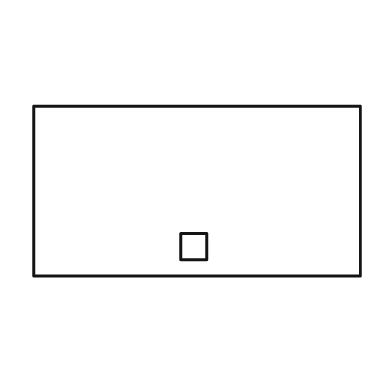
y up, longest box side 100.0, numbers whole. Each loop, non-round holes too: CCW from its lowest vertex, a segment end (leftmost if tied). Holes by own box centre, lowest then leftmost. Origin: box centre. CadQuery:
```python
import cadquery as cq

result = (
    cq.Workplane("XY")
    .moveTo(-50.0, -26.0)
    .lineTo(50.0, -26.0)
    .lineTo(50.0, 26.0)
    .lineTo(-50.0, 26.0)
    .close()
    .moveTo(-5.0, -21.0)
    .lineTo(3.0, -21.0)
    .lineTo(3.0, -13.0)
    .lineTo(-5.0, -13.0)
    .close()
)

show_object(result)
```